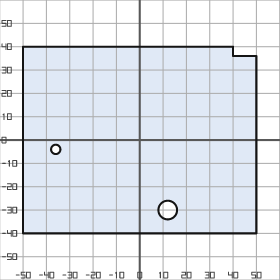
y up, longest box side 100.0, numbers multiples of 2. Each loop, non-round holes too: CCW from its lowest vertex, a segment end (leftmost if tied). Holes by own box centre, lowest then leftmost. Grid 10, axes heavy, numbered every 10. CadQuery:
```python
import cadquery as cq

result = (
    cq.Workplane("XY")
    .moveTo(-50.0, -40.0)
    .lineTo(50.0, -40.0)
    .lineTo(50.0, 36.0)
    .lineTo(40.0, 36.0)
    .lineTo(40.0, 40.0)
    .lineTo(-50.0, 40.0)
    .close()
    .moveTo(12.0, -30.0)
    .circle(4.0)
    .moveTo(-36.0, -4.0)
    .circle(2.0)
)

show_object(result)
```